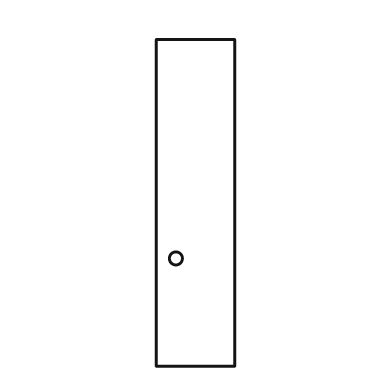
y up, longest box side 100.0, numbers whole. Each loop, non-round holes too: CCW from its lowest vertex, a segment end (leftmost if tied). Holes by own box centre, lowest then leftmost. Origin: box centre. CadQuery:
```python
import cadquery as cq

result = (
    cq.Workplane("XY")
    .moveTo(-12.0, -50.0)
    .lineTo(12.0, -50.0)
    .lineTo(12.0, 50.0)
    .lineTo(-12.0, 50.0)
    .close()
    .moveTo(-6.0, -17.0)
    .circle(2.0)
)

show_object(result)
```